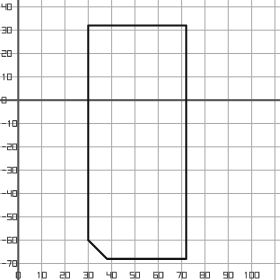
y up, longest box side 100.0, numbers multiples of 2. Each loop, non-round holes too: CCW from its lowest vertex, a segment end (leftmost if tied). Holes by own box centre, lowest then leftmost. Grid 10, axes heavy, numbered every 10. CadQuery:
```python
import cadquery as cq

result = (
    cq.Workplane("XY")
    .moveTo(38.0, -68.0)
    .lineTo(72.0, -68.0)
    .lineTo(72.0, 32.0)
    .lineTo(30.0, 32.0)
    .lineTo(30.0, -60.0)
    .close()
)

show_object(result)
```